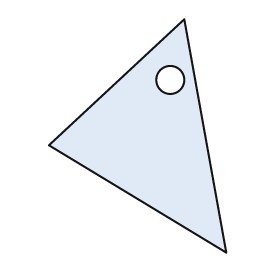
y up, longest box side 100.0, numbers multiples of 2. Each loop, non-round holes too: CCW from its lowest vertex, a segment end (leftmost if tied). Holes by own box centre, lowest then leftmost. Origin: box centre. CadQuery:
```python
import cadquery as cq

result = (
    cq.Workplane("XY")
    .moveTo(38.0, -50.0)
    .lineTo(20.0, 50.0)
    .lineTo(-38.0, -4.0)
    .close()
    .moveTo(14.0, 24.0)
    .circle(6.0)
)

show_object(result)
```